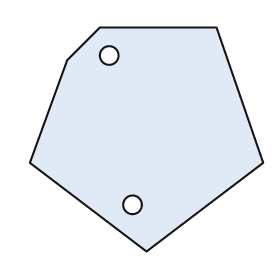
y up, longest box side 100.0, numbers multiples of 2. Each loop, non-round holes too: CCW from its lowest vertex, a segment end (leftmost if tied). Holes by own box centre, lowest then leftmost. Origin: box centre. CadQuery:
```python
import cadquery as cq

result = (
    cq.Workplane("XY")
    .moveTo(0.0, -48.0)
    .lineTo(50.0, -10.0)
    .lineTo(30.0, 48.0)
    .lineTo(-20.0, 48.0)
    .lineTo(-34.0, 34.0)
    .lineTo(-50.0, -10.0)
    .close()
    .moveTo(-6.0, -28.0)
    .circle(4.0)
    .moveTo(-16.0, 36.0)
    .circle(4.0)
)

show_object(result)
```